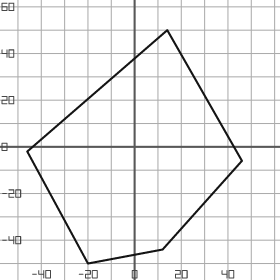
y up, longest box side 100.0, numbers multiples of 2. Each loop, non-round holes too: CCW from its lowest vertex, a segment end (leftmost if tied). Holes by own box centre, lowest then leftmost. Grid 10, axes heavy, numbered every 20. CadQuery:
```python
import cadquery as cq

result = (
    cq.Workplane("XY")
    .moveTo(-20.0, -50.0)
    .lineTo(12.0, -44.0)
    .lineTo(46.0, -6.0)
    .lineTo(14.0, 50.0)
    .lineTo(-46.0, -2.0)
    .close()
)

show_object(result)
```